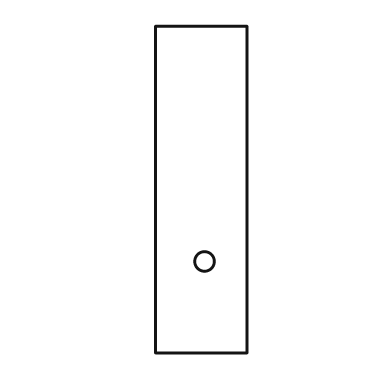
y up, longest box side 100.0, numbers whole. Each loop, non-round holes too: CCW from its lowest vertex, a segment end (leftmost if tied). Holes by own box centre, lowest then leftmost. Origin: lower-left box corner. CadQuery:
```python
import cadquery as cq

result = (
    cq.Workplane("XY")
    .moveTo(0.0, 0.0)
    .lineTo(28.0, 0.0)
    .lineTo(28.0, 100.0)
    .lineTo(0.0, 100.0)
    .close()
    .moveTo(15.0, 28.0)
    .circle(3.0)
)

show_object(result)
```